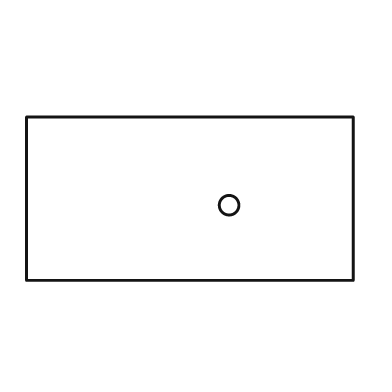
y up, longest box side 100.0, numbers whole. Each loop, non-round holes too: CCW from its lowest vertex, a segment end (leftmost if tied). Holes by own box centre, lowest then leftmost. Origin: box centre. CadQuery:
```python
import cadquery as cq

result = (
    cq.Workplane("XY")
    .moveTo(-50.0, -25.0)
    .lineTo(50.0, -25.0)
    .lineTo(50.0, 25.0)
    .lineTo(-50.0, 25.0)
    .close()
    .moveTo(12.0, -2.0)
    .circle(3.0)
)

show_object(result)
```